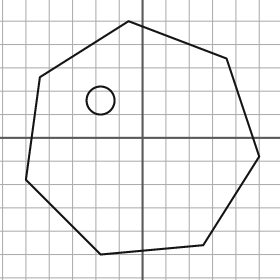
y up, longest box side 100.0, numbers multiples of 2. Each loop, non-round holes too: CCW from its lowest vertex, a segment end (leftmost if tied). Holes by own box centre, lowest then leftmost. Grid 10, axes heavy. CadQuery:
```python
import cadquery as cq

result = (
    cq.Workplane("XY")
    .moveTo(-18.0, -50.0)
    .lineTo(26.0, -46.0)
    .lineTo(50.0, -8.0)
    .lineTo(36.0, 34.0)
    .lineTo(-6.0, 50.0)
    .lineTo(-44.0, 26.0)
    .lineTo(-50.0, -18.0)
    .close()
    .moveTo(-18.0, 16.0)
    .circle(6.0)
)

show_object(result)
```